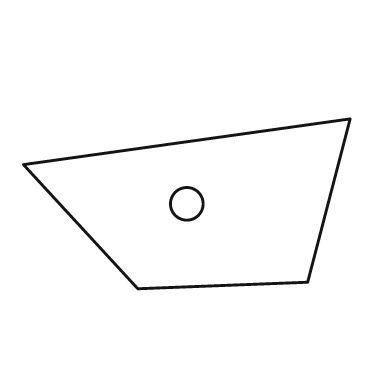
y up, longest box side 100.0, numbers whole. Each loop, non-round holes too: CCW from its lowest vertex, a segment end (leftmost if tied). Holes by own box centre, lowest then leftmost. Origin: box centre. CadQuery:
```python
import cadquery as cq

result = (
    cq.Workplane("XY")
    .moveTo(-15.0, -26.0)
    .lineTo(37.0, -24.0)
    .lineTo(50.0, 26.0)
    .lineTo(-50.0, 12.0)
    .close()
    .moveTo(0.0, 0.0)
    .circle(5.0)
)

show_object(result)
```